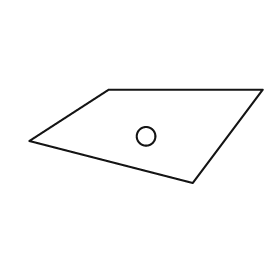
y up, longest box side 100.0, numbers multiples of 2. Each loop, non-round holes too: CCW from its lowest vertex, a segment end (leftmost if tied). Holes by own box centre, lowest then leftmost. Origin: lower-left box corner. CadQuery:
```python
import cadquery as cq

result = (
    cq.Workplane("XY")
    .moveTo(70.0, 0.0)
    .lineTo(100.0, 40.0)
    .lineTo(34.0, 40.0)
    .lineTo(0.0, 18.0)
    .close()
    .moveTo(50.0, 20.0)
    .circle(4.0)
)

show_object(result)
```